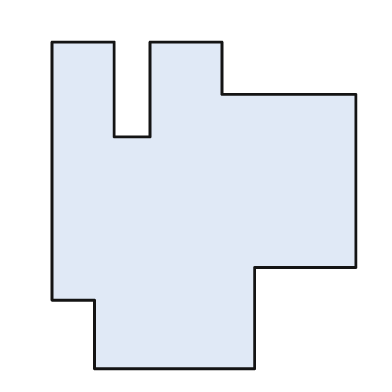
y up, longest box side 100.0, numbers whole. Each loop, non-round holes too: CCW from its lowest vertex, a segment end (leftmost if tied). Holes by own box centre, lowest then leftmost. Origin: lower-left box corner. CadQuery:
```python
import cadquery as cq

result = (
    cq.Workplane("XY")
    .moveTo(13.0, 0.0)
    .lineTo(62.0, 0.0)
    .lineTo(62.0, 31.0)
    .lineTo(93.0, 31.0)
    .lineTo(93.0, 84.0)
    .lineTo(52.0, 84.0)
    .lineTo(52.0, 100.0)
    .lineTo(30.0, 100.0)
    .lineTo(30.0, 71.0)
    .lineTo(19.0, 71.0)
    .lineTo(19.0, 100.0)
    .lineTo(0.0, 100.0)
    .lineTo(0.0, 21.0)
    .lineTo(13.0, 21.0)
    .close()
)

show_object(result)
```